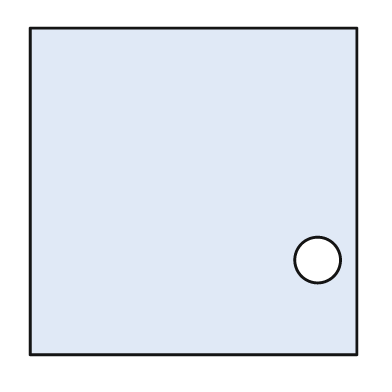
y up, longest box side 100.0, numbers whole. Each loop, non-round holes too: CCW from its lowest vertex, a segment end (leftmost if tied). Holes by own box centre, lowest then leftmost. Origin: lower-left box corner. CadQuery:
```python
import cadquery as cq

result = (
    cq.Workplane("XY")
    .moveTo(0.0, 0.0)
    .lineTo(100.0, 0.0)
    .lineTo(100.0, 100.0)
    .lineTo(0.0, 100.0)
    .close()
    .moveTo(88.0, 29.0)
    .circle(7.0)
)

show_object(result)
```